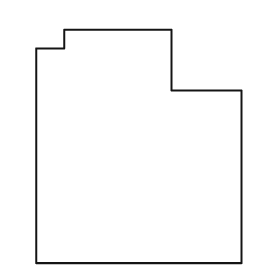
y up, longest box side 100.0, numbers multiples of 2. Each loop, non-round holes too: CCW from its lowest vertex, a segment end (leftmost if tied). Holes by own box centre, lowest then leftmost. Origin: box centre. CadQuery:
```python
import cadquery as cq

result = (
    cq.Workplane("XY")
    .moveTo(-44.0, -50.0)
    .lineTo(44.0, -50.0)
    .lineTo(44.0, 24.0)
    .lineTo(14.0, 24.0)
    .lineTo(14.0, 50.0)
    .lineTo(-32.0, 50.0)
    .lineTo(-32.0, 42.0)
    .lineTo(-44.0, 42.0)
    .close()
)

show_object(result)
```